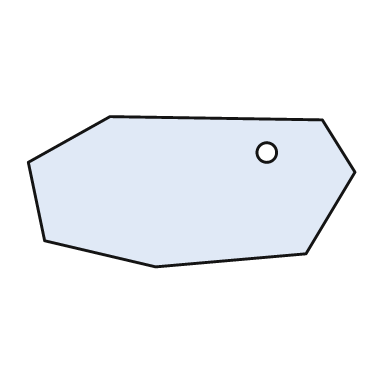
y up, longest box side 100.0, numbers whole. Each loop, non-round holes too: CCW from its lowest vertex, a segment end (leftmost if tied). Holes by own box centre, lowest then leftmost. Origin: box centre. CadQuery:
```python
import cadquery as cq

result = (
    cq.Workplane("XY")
    .moveTo(-11.0, -23.0)
    .lineTo(35.0, -19.0)
    .lineTo(50.0, 6.0)
    .lineTo(40.0, 22.0)
    .lineTo(-25.0, 23.0)
    .lineTo(-50.0, 9.0)
    .lineTo(-45.0, -15.0)
    .close()
    .moveTo(23.0, 12.0)
    .circle(3.0)
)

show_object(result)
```